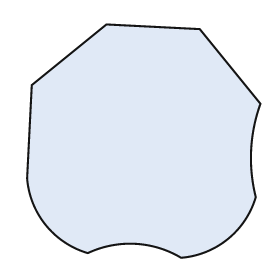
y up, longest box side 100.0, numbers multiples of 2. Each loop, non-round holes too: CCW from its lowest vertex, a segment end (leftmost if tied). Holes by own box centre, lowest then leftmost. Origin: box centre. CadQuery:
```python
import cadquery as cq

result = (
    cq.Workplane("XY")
    .moveTo(16.0, -50.0)
    .threePointArc((36.0, -42.0), (48.0, -24.0))
    .threePointArc((46.0, -4.0), (50.0, 16.0))
    .lineTo(24.0, 48.0)
    .lineTo(-16.0, 50.0)
    .lineTo(-48.0, 24.0)
    .lineTo(-50.0, -16.0)
    .threePointArc((-42.0, -36.0), (-24.0, -48.0))
    .threePointArc((-4.0, -44.0), (16.0, -50.0))
    .close()
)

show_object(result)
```